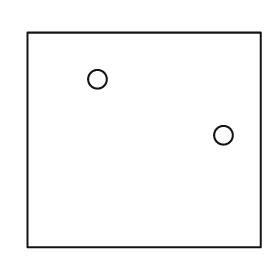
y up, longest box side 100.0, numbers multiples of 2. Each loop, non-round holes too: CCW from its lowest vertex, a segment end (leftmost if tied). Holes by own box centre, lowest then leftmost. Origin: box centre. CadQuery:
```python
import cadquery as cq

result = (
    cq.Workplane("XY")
    .moveTo(-50.0, -46.0)
    .lineTo(50.0, -46.0)
    .lineTo(50.0, 46.0)
    .lineTo(-50.0, 46.0)
    .close()
    .moveTo(34.0, 2.0)
    .circle(4.0)
    .moveTo(-20.0, 26.0)
    .circle(4.0)
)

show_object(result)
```